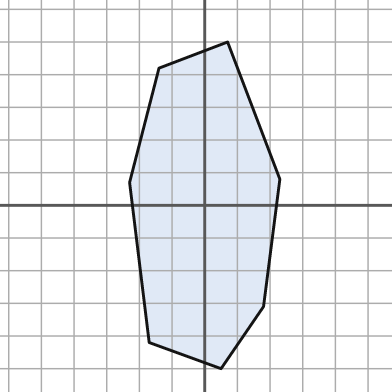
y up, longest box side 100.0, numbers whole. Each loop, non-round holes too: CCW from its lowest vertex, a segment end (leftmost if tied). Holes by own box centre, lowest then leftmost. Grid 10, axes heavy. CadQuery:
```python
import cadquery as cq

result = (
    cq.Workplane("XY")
    .moveTo(5.0, -50.0)
    .lineTo(18.0, -31.0)
    .lineTo(23.0, 8.0)
    .lineTo(7.0, 50.0)
    .lineTo(-14.0, 42.0)
    .lineTo(-23.0, 7.0)
    .lineTo(-17.0, -42.0)
    .close()
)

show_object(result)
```